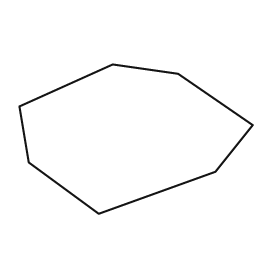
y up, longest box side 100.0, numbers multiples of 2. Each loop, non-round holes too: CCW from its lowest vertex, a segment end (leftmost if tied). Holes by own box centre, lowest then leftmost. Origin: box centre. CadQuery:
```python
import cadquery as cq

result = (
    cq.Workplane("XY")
    .moveTo(-16.0, -32.0)
    .lineTo(34.0, -14.0)
    .lineTo(50.0, 6.0)
    .lineTo(18.0, 28.0)
    .lineTo(-10.0, 32.0)
    .lineTo(-50.0, 14.0)
    .lineTo(-46.0, -10.0)
    .close()
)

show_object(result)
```